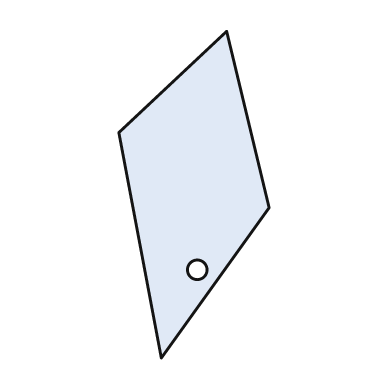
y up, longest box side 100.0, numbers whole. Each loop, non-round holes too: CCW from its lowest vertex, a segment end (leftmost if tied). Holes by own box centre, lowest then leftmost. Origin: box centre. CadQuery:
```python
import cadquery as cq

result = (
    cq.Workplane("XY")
    .moveTo(-10.0, -50.0)
    .lineTo(23.0, -4.0)
    .lineTo(10.0, 50.0)
    .lineTo(-23.0, 19.0)
    .close()
    .moveTo(1.0, -23.0)
    .circle(3.0)
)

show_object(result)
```